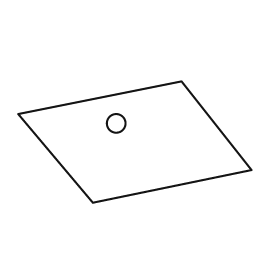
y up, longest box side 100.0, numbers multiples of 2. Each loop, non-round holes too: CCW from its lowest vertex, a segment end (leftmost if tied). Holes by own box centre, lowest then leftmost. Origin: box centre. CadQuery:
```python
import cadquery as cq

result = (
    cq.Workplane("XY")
    .moveTo(-18.0, -26.0)
    .lineTo(50.0, -12.0)
    .lineTo(20.0, 26.0)
    .lineTo(-50.0, 12.0)
    .close()
    .moveTo(-8.0, 8.0)
    .circle(4.0)
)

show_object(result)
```